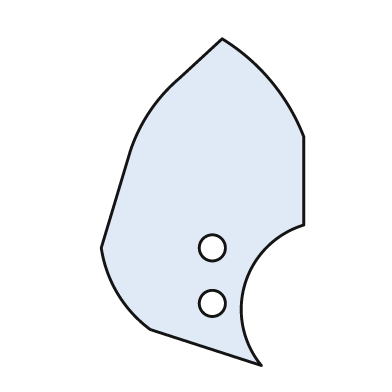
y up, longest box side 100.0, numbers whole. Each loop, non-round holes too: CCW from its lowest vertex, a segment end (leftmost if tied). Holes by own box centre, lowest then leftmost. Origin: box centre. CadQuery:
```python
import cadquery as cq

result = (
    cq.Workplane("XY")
    .moveTo(18.0, -50.0)
    .threePointArc((13.0, -25.0), (31.0, -7.0))
    .lineTo(31.0, 20.0)
    .threePointArc((21.0, 37.0), (6.0, 50.0))
    .lineTo(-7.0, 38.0)
    .threePointArc((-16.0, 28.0), (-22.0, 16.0))
    .lineTo(-31.0, -14.0)
    .threePointArc((-26.0, -28.0), (-16.0, -39.0))
    .close()
    .moveTo(3.0, -31.0)
    .circle(4.0)
    .moveTo(3.0, -14.0)
    .circle(4.0)
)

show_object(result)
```